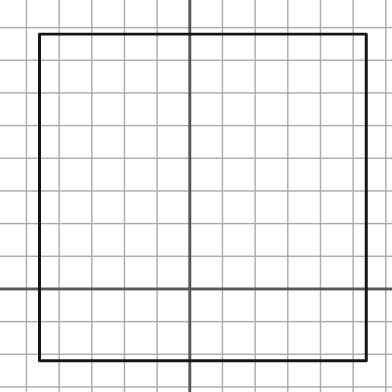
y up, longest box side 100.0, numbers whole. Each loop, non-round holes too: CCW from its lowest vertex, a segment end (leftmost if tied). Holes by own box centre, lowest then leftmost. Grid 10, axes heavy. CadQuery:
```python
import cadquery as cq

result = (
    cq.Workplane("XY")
    .moveTo(-46.0, -22.0)
    .lineTo(54.0, -22.0)
    .lineTo(54.0, 78.0)
    .lineTo(-46.0, 78.0)
    .close()
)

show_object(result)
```